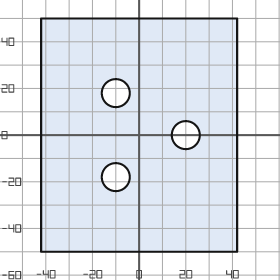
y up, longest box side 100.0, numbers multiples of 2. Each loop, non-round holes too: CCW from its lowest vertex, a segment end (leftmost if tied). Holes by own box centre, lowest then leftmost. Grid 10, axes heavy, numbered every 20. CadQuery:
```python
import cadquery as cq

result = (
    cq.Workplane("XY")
    .moveTo(-42.0, -50.0)
    .lineTo(42.0, -50.0)
    .lineTo(42.0, 50.0)
    .lineTo(-42.0, 50.0)
    .close()
    .moveTo(-10.0, -18.0)
    .circle(6.0)
    .moveTo(20.0, 0.0)
    .circle(6.0)
    .moveTo(-10.0, 18.0)
    .circle(6.0)
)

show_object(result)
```